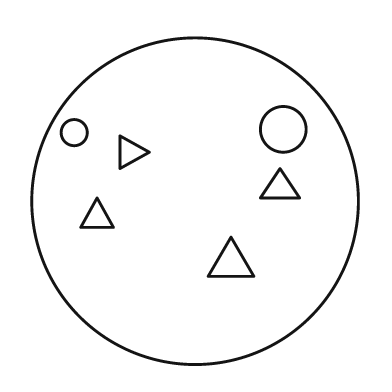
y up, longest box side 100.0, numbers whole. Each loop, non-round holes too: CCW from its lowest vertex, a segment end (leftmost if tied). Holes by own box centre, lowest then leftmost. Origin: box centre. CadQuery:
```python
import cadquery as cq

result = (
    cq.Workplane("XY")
    .moveTo(0.0, 0.0)
    .circle(50.0)
    .moveTo(4.0, -23.0)
    .lineTo(18.0, -23.0)
    .lineTo(11.0, -11.0)
    .close()
    .moveTo(-35.0, -8.0)
    .lineTo(-25.0, -8.0)
    .lineTo(-30.0, 1.0)
    .close()
    .moveTo(20.0, 1.0)
    .lineTo(32.0, 1.0)
    .lineTo(26.0, 10.0)
    .close()
    .moveTo(-23.0, 10.0)
    .lineTo(-14.0, 15.0)
    .lineTo(-23.0, 20.0)
    .close()
    .moveTo(-37.0, 21.0)
    .circle(4.0)
    .moveTo(27.0, 22.0)
    .circle(7.0)
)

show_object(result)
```